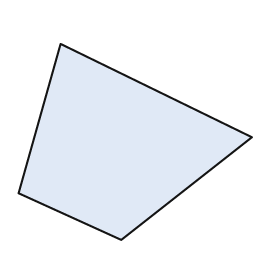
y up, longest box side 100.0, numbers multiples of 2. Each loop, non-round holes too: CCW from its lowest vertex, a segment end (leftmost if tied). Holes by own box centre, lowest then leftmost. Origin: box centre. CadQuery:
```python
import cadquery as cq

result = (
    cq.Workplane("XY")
    .moveTo(-6.0, -42.0)
    .lineTo(50.0, 2.0)
    .lineTo(-32.0, 42.0)
    .lineTo(-50.0, -22.0)
    .close()
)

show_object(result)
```